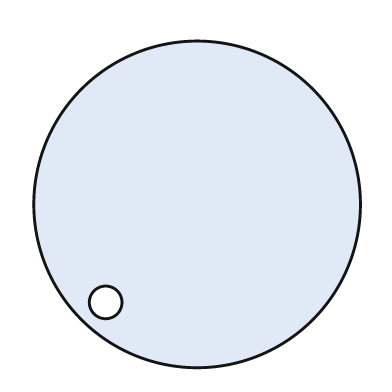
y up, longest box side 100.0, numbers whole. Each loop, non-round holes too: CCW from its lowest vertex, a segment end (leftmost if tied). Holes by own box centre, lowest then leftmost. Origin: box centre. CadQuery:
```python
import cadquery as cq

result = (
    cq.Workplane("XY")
    .moveTo(0.0, 0.0)
    .circle(50.0)
    .moveTo(-28.0, -30.0)
    .circle(5.0)
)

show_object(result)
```